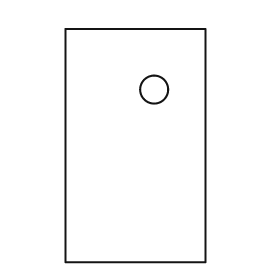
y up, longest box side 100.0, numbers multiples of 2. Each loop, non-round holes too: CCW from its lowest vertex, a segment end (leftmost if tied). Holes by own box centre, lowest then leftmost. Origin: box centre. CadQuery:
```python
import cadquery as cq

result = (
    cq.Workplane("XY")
    .moveTo(-30.0, -50.0)
    .lineTo(30.0, -50.0)
    .lineTo(30.0, 50.0)
    .lineTo(-30.0, 50.0)
    .close()
    .moveTo(8.0, 24.0)
    .circle(6.0)
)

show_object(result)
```